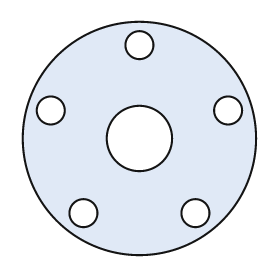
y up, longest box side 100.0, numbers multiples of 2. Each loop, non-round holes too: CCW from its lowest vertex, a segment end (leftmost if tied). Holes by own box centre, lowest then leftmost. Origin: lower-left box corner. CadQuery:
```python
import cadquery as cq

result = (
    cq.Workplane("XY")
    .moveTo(50.0, 50.0)
    .circle(50.0)
    .moveTo(26.0, 18.0)
    .circle(6.0)
    .moveTo(74.0, 18.0)
    .circle(6.0)
    .moveTo(50.0, 50.0)
    .circle(14.0)
    .moveTo(12.0, 62.0)
    .circle(6.0)
    .moveTo(88.0, 62.0)
    .circle(6.0)
    .moveTo(50.0, 90.0)
    .circle(6.0)
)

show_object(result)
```